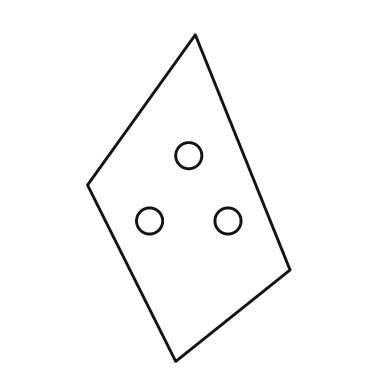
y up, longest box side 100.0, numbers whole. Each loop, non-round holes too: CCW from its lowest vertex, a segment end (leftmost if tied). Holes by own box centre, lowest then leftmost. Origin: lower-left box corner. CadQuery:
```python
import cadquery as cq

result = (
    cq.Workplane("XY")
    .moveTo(27.0, 0.0)
    .lineTo(62.0, 28.0)
    .lineTo(33.0, 100.0)
    .lineTo(0.0, 54.0)
    .close()
    .moveTo(19.0, 43.0)
    .circle(4.0)
    .moveTo(43.0, 43.0)
    .circle(4.0)
    .moveTo(31.0, 63.0)
    .circle(4.0)
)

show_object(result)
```